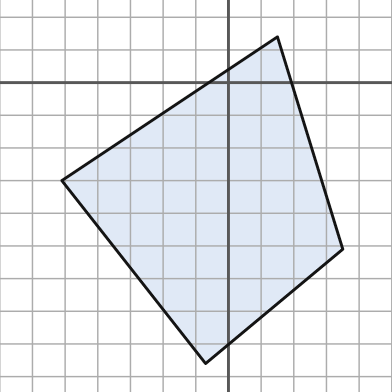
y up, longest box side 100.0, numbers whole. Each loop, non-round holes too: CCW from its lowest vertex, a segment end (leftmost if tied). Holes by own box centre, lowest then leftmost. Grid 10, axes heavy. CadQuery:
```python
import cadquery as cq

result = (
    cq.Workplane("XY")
    .moveTo(-7.0, -86.0)
    .lineTo(35.0, -51.0)
    .lineTo(15.0, 14.0)
    .lineTo(-51.0, -30.0)
    .close()
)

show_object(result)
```